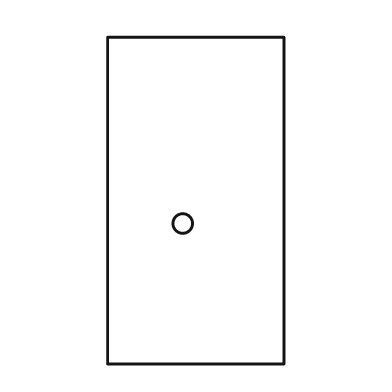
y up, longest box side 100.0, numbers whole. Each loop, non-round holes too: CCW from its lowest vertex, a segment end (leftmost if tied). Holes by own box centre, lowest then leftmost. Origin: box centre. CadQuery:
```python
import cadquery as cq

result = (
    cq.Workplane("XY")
    .moveTo(-27.0, -50.0)
    .lineTo(27.0, -50.0)
    .lineTo(27.0, 50.0)
    .lineTo(-27.0, 50.0)
    .close()
    .moveTo(-4.0, -7.0)
    .circle(3.0)
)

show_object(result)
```